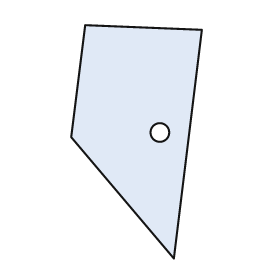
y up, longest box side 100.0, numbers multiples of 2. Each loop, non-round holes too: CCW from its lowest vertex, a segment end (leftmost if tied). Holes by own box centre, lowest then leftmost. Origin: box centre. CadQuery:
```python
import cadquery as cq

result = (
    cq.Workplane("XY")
    .moveTo(16.0, -50.0)
    .lineTo(28.0, 48.0)
    .lineTo(-22.0, 50.0)
    .lineTo(-28.0, 2.0)
    .close()
    .moveTo(10.0, 4.0)
    .circle(4.0)
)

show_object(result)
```